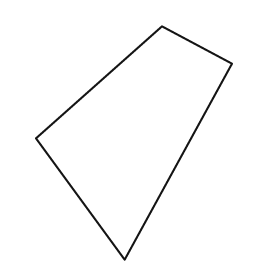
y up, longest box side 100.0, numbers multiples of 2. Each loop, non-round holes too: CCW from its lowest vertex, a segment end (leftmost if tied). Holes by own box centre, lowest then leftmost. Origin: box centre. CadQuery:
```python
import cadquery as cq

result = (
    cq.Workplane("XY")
    .moveTo(-4.0, -50.0)
    .lineTo(42.0, 34.0)
    .lineTo(12.0, 50.0)
    .lineTo(-42.0, 2.0)
    .close()
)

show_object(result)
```